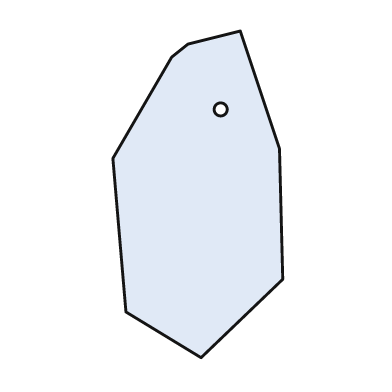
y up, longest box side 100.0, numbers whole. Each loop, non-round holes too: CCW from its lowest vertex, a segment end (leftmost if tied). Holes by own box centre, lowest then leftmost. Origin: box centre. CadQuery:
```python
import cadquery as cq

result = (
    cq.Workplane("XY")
    .moveTo(1.0, -50.0)
    .lineTo(26.0, -26.0)
    .lineTo(25.0, 14.0)
    .lineTo(13.0, 50.0)
    .lineTo(-3.0, 46.0)
    .lineTo(-8.0, 42.0)
    .lineTo(-26.0, 11.0)
    .lineTo(-22.0, -36.0)
    .close()
    .moveTo(7.0, 26.0)
    .circle(2.0)
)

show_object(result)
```